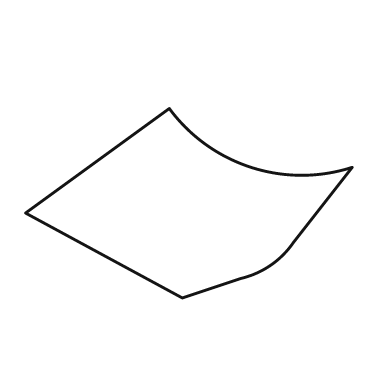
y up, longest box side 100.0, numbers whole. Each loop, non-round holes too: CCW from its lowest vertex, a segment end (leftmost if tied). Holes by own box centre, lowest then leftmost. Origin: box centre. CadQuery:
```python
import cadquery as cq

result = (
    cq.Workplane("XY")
    .moveTo(-2.0, -29.0)
    .lineTo(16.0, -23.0)
    .threePointArc((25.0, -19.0), (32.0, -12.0))
    .lineTo(50.0, 11.0)
    .threePointArc((19.0, 11.0), (-6.0, 29.0))
    .lineTo(-50.0, -3.0)
    .close()
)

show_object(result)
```